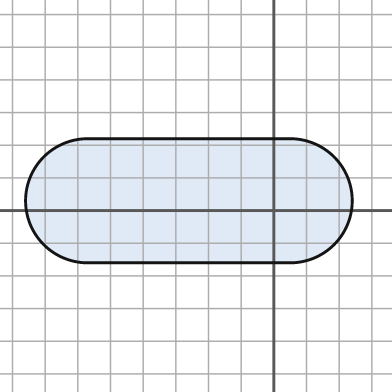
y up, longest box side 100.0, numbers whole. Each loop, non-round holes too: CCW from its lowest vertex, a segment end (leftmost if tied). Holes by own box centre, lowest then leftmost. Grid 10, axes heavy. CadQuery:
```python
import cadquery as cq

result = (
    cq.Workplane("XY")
    .moveTo(-57.0, -16.0)
    .lineTo(5.0, -16.0)
    .threePointArc((24.0, 3.0), (5.0, 22.0))
    .lineTo(-57.0, 22.0)
    .threePointArc((-76.0, 3.0), (-57.0, -16.0))
    .close()
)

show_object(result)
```